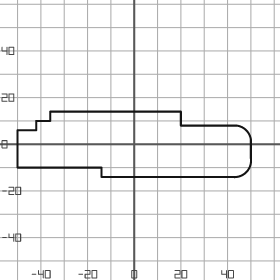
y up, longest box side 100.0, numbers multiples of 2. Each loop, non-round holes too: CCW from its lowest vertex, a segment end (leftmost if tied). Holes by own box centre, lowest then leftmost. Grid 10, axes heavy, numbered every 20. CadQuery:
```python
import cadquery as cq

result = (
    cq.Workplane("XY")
    .moveTo(-14.0, -14.0)
    .lineTo(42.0, -14.0)
    .threePointArc((48.0, -12.0), (50.0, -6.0))
    .lineTo(50.0, 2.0)
    .threePointArc((48.0, 6.0), (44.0, 8.0))
    .lineTo(20.0, 8.0)
    .lineTo(20.0, 14.0)
    .lineTo(-36.0, 14.0)
    .lineTo(-36.0, 10.0)
    .lineTo(-42.0, 10.0)
    .lineTo(-42.0, 6.0)
    .lineTo(-50.0, 6.0)
    .lineTo(-50.0, -10.0)
    .lineTo(-14.0, -10.0)
    .close()
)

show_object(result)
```